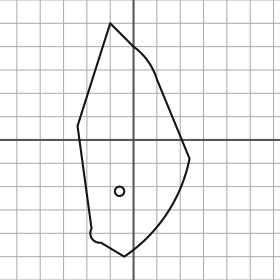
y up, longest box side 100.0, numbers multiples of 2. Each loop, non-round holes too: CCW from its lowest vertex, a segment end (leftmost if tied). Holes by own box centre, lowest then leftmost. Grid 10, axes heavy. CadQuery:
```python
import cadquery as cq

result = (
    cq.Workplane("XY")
    .moveTo(-4.0, -50.0)
    .threePointArc((14.0, -32.0), (24.0, -8.0))
    .lineTo(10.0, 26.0)
    .threePointArc((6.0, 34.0), (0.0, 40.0))
    .lineTo(-10.0, 50.0)
    .lineTo(-24.0, 6.0)
    .lineTo(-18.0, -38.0)
    .threePointArc((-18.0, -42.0), (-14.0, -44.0))
    .close()
    .moveTo(-6.0, -22.0)
    .circle(2.0)
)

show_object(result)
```